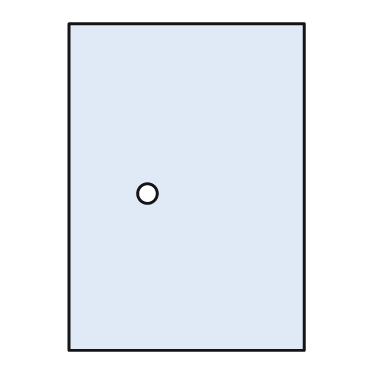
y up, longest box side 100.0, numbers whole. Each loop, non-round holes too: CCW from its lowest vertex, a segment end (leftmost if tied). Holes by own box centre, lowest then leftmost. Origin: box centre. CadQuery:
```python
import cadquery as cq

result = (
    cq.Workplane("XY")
    .moveTo(-36.0, -50.0)
    .lineTo(36.0, -50.0)
    .lineTo(36.0, 50.0)
    .lineTo(-36.0, 50.0)
    .close()
    .moveTo(-12.0, -2.0)
    .circle(3.0)
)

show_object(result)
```